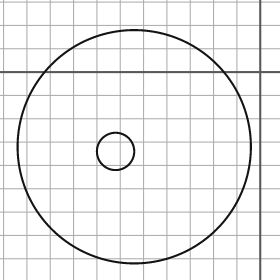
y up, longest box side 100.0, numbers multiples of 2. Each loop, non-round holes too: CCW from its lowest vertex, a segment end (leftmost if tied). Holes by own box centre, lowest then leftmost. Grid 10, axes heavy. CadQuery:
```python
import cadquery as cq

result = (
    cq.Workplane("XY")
    .moveTo(-54.0, -32.0)
    .circle(50.0)
    .moveTo(-62.0, -34.0)
    .circle(8.0)
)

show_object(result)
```